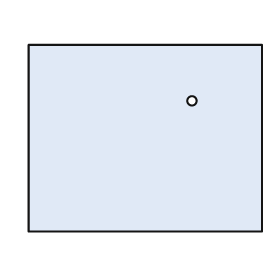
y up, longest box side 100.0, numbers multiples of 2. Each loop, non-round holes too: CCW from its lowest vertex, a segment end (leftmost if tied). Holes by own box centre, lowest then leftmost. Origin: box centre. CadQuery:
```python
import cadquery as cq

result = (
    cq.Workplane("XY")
    .moveTo(-50.0, -40.0)
    .lineTo(50.0, -40.0)
    .lineTo(50.0, 40.0)
    .lineTo(-50.0, 40.0)
    .close()
    .moveTo(20.0, 16.0)
    .circle(2.0)
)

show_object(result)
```